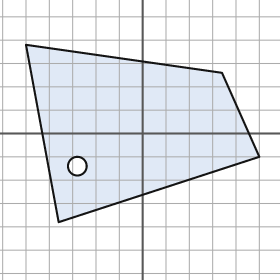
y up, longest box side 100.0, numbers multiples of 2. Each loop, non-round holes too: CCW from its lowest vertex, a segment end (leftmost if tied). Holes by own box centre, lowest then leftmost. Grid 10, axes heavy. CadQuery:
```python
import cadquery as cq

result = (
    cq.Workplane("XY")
    .moveTo(-36.0, -38.0)
    .lineTo(50.0, -10.0)
    .lineTo(34.0, 26.0)
    .lineTo(-50.0, 38.0)
    .close()
    .moveTo(-28.0, -14.0)
    .circle(4.0)
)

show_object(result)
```